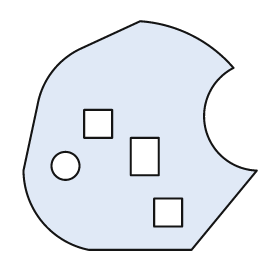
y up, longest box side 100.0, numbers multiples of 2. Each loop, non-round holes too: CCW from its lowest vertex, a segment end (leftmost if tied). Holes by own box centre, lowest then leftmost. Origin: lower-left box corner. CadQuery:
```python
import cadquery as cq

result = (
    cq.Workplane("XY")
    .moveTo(28.0, 0.0)
    .lineTo(72.0, 0.0)
    .lineTo(100.0, 34.0)
    .threePointArc((78.0, 52.0), (90.0, 78.0))
    .threePointArc((72.0, 92.0), (50.0, 98.0))
    .lineTo(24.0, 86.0)
    .threePointArc((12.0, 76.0), (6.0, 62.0))
    .lineTo(0.0, 34.0)
    .threePointArc((8.0, 12.0), (28.0, 0.0))
    .close()
    .moveTo(56.0, 10.0)
    .lineTo(68.0, 10.0)
    .lineTo(68.0, 22.0)
    .lineTo(56.0, 22.0)
    .close()
    .moveTo(18.0, 36.0)
    .circle(6.0)
    .moveTo(46.0, 32.0)
    .lineTo(58.0, 32.0)
    .lineTo(58.0, 48.0)
    .lineTo(46.0, 48.0)
    .close()
    .moveTo(26.0, 48.0)
    .lineTo(38.0, 48.0)
    .lineTo(38.0, 60.0)
    .lineTo(26.0, 60.0)
    .close()
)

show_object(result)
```